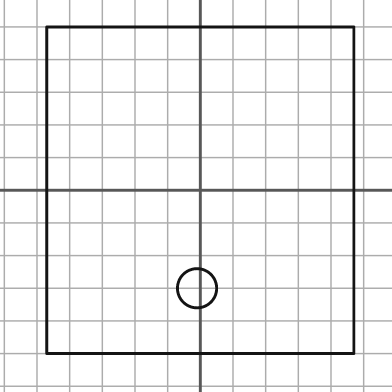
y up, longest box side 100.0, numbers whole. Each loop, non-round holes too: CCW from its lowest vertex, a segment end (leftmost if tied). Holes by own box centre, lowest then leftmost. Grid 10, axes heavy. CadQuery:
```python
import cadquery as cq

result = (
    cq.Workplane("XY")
    .moveTo(-47.0, -50.0)
    .lineTo(47.0, -50.0)
    .lineTo(47.0, 50.0)
    .lineTo(-47.0, 50.0)
    .close()
    .moveTo(-1.0, -30.0)
    .circle(6.0)
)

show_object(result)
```